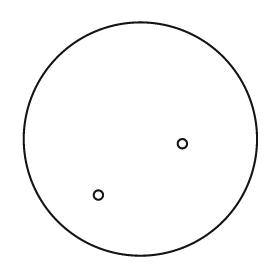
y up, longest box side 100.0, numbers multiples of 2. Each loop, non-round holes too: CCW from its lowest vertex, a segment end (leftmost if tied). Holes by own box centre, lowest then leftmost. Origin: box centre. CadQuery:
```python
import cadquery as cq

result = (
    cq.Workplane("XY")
    .moveTo(0.0, 0.0)
    .circle(50.0)
    .moveTo(-18.0, -24.0)
    .circle(2.0)
    .moveTo(18.0, -2.0)
    .circle(2.0)
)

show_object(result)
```